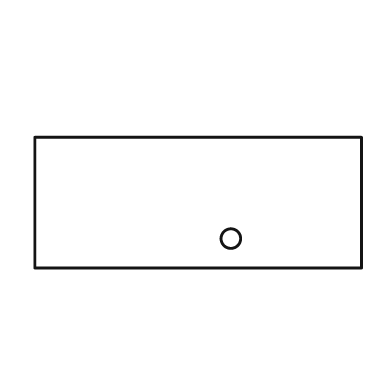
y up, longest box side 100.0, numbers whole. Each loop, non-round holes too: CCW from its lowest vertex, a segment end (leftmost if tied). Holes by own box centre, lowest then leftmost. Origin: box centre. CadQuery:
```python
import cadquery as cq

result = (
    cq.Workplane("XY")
    .moveTo(-50.0, -20.0)
    .lineTo(50.0, -20.0)
    .lineTo(50.0, 20.0)
    .lineTo(-50.0, 20.0)
    .close()
    .moveTo(10.0, -11.0)
    .circle(3.0)
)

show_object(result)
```